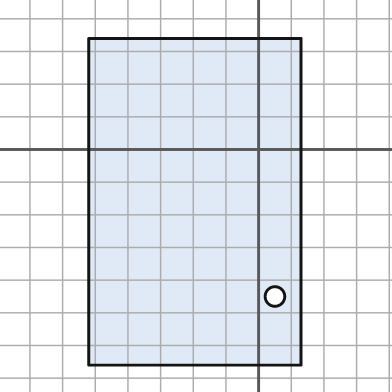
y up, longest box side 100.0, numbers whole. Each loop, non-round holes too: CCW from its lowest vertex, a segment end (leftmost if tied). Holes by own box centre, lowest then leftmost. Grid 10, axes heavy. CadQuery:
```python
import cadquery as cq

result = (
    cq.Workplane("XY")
    .moveTo(-52.0, -66.0)
    .lineTo(13.0, -66.0)
    .lineTo(13.0, 34.0)
    .lineTo(-52.0, 34.0)
    .close()
    .moveTo(5.0, -45.0)
    .circle(3.0)
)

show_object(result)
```